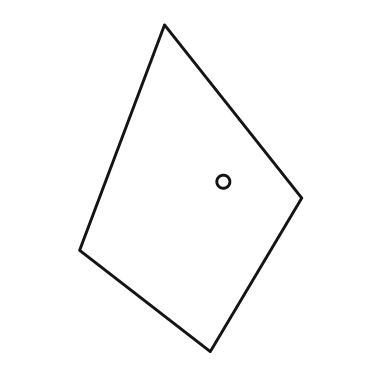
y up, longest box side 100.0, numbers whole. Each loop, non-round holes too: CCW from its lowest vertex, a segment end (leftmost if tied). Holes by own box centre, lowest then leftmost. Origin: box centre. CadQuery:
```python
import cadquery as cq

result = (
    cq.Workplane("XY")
    .moveTo(6.0, -50.0)
    .lineTo(34.0, -3.0)
    .lineTo(-8.0, 50.0)
    .lineTo(-34.0, -19.0)
    .close()
    .moveTo(10.0, 2.0)
    .circle(2.0)
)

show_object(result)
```